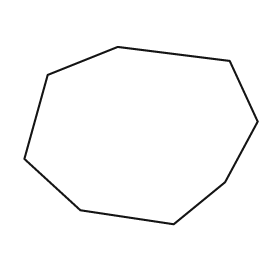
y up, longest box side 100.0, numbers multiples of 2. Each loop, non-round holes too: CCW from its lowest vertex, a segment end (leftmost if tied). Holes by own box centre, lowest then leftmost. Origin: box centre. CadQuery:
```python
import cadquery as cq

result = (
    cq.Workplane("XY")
    .moveTo(14.0, -38.0)
    .lineTo(36.0, -20.0)
    .lineTo(50.0, 6.0)
    .lineTo(38.0, 32.0)
    .lineTo(-10.0, 38.0)
    .lineTo(-40.0, 26.0)
    .lineTo(-50.0, -10.0)
    .lineTo(-26.0, -32.0)
    .close()
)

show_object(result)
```